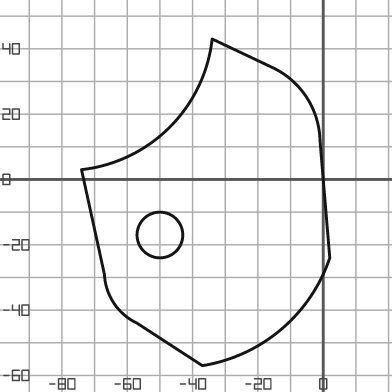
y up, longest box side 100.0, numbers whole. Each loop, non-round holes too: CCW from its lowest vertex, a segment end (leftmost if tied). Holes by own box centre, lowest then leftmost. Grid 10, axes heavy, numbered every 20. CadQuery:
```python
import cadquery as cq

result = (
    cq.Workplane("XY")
    .moveTo(-37.0, -57.0)
    .threePointArc((-13.0, -46.0), (2.0, -24.0))
    .lineTo(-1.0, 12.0)
    .threePointArc((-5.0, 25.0), (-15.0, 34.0))
    .lineTo(-34.0, 43.0)
    .threePointArc((-47.0, 16.0), (-74.0, 3.0))
    .lineTo(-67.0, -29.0)
    .threePointArc((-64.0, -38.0), (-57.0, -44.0))
    .close()
    .moveTo(-50.0, -17.0)
    .circle(7.0)
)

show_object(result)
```